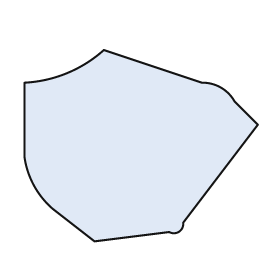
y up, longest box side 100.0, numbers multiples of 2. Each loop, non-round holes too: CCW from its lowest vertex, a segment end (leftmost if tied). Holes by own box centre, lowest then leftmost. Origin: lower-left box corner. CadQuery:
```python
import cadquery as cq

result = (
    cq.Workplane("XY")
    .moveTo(30.0, 0.0)
    .lineTo(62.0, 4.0)
    .threePointArc((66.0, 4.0), (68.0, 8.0))
    .lineTo(100.0, 50.0)
    .lineTo(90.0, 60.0)
    .threePointArc((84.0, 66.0), (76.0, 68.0))
    .lineTo(34.0, 82.0)
    .threePointArc((18.0, 72.0), (0.0, 68.0))
    .lineTo(0.0, 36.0)
    .threePointArc((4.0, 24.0), (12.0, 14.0))
    .close()
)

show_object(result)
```